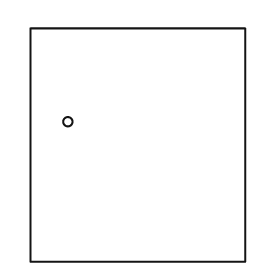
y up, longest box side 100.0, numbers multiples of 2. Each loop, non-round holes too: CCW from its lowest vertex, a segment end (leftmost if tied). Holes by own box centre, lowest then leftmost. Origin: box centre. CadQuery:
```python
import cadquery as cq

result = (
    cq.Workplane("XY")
    .moveTo(-46.0, -50.0)
    .lineTo(46.0, -50.0)
    .lineTo(46.0, 50.0)
    .lineTo(-46.0, 50.0)
    .close()
    .moveTo(-30.0, 10.0)
    .circle(2.0)
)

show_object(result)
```